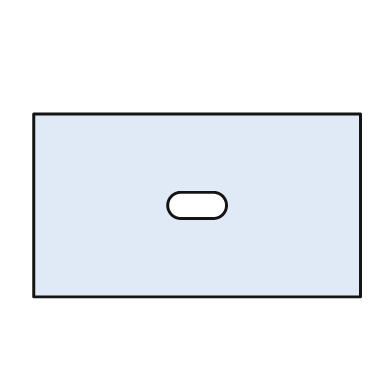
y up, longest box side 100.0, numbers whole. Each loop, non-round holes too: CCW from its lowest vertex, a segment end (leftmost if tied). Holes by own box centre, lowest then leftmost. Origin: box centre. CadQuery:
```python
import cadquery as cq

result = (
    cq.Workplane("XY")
    .moveTo(-50.0, -28.0)
    .lineTo(50.0, -28.0)
    .lineTo(50.0, 28.0)
    .lineTo(-50.0, 28.0)
    .close()
    .moveTo(-5.0, -4.0)
    .lineTo(5.0, -4.0)
    .threePointArc((9.0, 0.0), (5.0, 4.0))
    .lineTo(-5.0, 4.0)
    .threePointArc((-9.0, 0.0), (-5.0, -4.0))
    .close()
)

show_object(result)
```